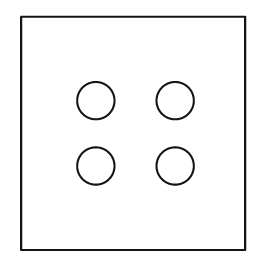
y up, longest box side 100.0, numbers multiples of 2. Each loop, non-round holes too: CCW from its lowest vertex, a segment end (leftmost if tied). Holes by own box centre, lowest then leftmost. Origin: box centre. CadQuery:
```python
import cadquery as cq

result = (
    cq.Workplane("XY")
    .moveTo(-48.0, -50.0)
    .lineTo(48.0, -50.0)
    .lineTo(48.0, 50.0)
    .lineTo(-48.0, 50.0)
    .close()
    .moveTo(-16.0, -14.0)
    .circle(8.0)
    .moveTo(18.0, -14.0)
    .circle(8.0)
    .moveTo(-16.0, 14.0)
    .circle(8.0)
    .moveTo(18.0, 14.0)
    .circle(8.0)
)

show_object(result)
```